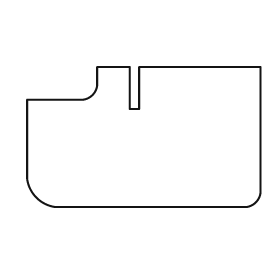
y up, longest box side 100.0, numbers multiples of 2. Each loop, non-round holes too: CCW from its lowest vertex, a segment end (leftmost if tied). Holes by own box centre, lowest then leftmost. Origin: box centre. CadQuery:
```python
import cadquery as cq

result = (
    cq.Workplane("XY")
    .moveTo(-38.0, -30.0)
    .lineTo(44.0, -30.0)
    .threePointArc((48.0, -28.0), (50.0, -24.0))
    .lineTo(50.0, 30.0)
    .lineTo(-2.0, 30.0)
    .lineTo(-2.0, 12.0)
    .lineTo(-6.0, 12.0)
    .lineTo(-6.0, 30.0)
    .lineTo(-20.0, 30.0)
    .lineTo(-20.0, 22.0)
    .threePointArc((-22.0, 18.0), (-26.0, 16.0))
    .lineTo(-50.0, 16.0)
    .lineTo(-50.0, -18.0)
    .threePointArc((-46.0, -26.0), (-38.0, -30.0))
    .close()
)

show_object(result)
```